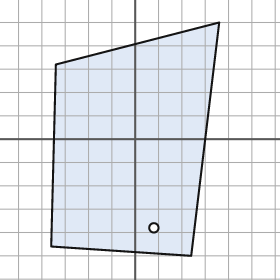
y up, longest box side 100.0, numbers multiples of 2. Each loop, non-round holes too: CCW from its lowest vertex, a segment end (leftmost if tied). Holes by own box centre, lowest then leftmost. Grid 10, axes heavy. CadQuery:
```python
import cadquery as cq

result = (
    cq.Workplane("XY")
    .moveTo(24.0, -50.0)
    .lineTo(36.0, 50.0)
    .lineTo(-34.0, 32.0)
    .lineTo(-36.0, -46.0)
    .close()
    .moveTo(8.0, -38.0)
    .circle(2.0)
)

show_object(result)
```